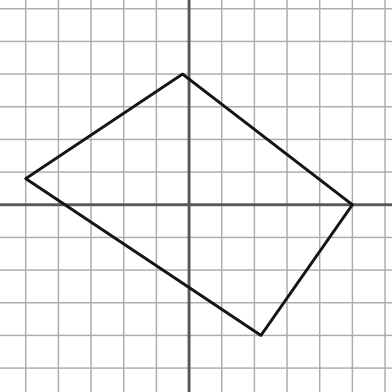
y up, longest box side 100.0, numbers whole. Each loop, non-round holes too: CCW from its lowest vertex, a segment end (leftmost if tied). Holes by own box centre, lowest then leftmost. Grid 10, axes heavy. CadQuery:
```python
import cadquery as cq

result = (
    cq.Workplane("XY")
    .moveTo(22.0, -40.0)
    .lineTo(50.0, 0.0)
    .lineTo(-2.0, 40.0)
    .lineTo(-50.0, 8.0)
    .close()
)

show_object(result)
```